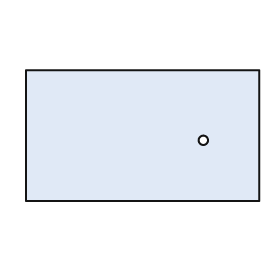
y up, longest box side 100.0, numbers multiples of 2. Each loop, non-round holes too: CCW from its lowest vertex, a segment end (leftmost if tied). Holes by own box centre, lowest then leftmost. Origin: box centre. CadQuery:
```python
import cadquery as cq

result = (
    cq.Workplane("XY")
    .moveTo(-50.0, -28.0)
    .lineTo(50.0, -28.0)
    .lineTo(50.0, 28.0)
    .lineTo(-50.0, 28.0)
    .close()
    .moveTo(26.0, -2.0)
    .circle(2.0)
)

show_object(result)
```